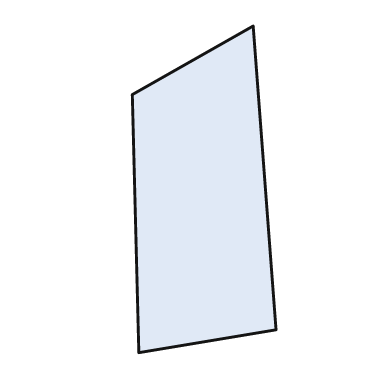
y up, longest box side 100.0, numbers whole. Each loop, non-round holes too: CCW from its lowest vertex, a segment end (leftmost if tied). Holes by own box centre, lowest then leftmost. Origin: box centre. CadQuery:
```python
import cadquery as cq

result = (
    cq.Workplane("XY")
    .moveTo(-20.0, -50.0)
    .lineTo(22.0, -43.0)
    .lineTo(15.0, 50.0)
    .lineTo(-22.0, 29.0)
    .close()
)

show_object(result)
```